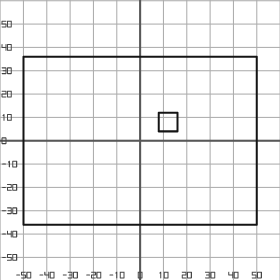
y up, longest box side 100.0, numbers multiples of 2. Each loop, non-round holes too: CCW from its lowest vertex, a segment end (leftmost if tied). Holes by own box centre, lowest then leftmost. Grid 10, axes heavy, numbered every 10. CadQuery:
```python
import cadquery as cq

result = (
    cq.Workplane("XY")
    .moveTo(-50.0, -36.0)
    .lineTo(50.0, -36.0)
    .lineTo(50.0, 36.0)
    .lineTo(-50.0, 36.0)
    .close()
    .moveTo(8.0, 4.0)
    .lineTo(16.0, 4.0)
    .lineTo(16.0, 12.0)
    .lineTo(8.0, 12.0)
    .close()
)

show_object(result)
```